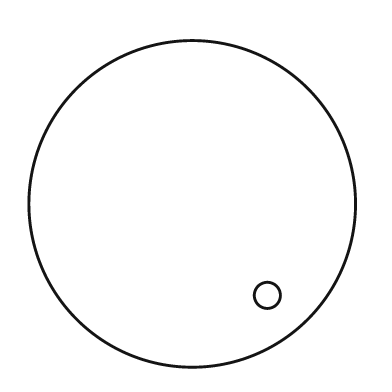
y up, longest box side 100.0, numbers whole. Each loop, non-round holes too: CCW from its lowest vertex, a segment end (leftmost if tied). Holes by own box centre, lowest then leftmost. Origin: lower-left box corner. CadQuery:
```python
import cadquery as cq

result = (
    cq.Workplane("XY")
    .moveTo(50.0, 50.0)
    .circle(50.0)
    .moveTo(73.0, 22.0)
    .circle(4.0)
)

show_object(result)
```